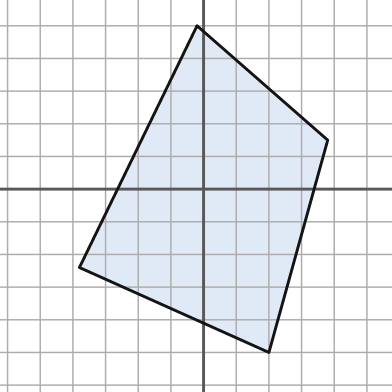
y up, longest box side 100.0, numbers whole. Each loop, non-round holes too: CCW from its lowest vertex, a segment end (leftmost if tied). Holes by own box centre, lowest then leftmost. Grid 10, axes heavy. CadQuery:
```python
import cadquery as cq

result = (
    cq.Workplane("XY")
    .moveTo(20.0, -50.0)
    .lineTo(38.0, 15.0)
    .lineTo(-2.0, 50.0)
    .lineTo(-38.0, -24.0)
    .close()
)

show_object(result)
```